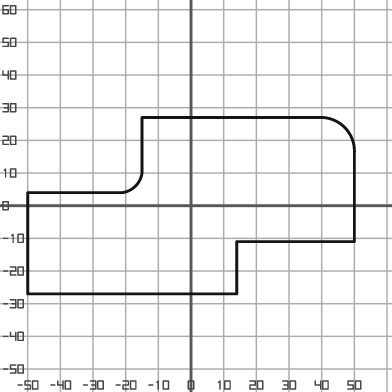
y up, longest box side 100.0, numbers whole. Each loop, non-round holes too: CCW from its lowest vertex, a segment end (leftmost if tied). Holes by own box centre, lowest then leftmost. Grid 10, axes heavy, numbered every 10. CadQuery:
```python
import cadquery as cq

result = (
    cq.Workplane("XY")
    .moveTo(-50.0, -27.0)
    .lineTo(14.0, -27.0)
    .lineTo(14.0, -11.0)
    .lineTo(50.0, -11.0)
    .lineTo(50.0, 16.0)
    .threePointArc((47.0, 24.0), (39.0, 27.0))
    .lineTo(-15.0, 27.0)
    .lineTo(-15.0, 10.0)
    .threePointArc((-17.0, 6.0), (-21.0, 4.0))
    .lineTo(-50.0, 4.0)
    .close()
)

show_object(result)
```